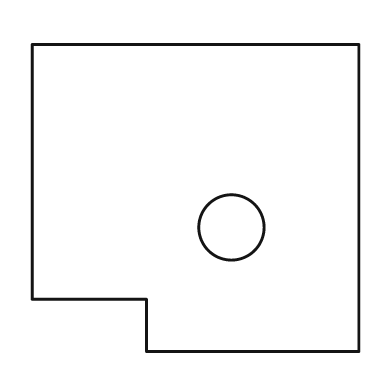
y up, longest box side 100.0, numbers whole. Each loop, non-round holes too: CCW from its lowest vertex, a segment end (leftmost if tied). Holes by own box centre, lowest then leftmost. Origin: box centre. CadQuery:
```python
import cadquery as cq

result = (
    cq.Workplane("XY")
    .moveTo(-15.0, -47.0)
    .lineTo(50.0, -47.0)
    .lineTo(50.0, 47.0)
    .lineTo(-50.0, 47.0)
    .lineTo(-50.0, -31.0)
    .lineTo(-15.0, -31.0)
    .close()
    .moveTo(11.0, -9.0)
    .circle(10.0)
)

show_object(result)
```